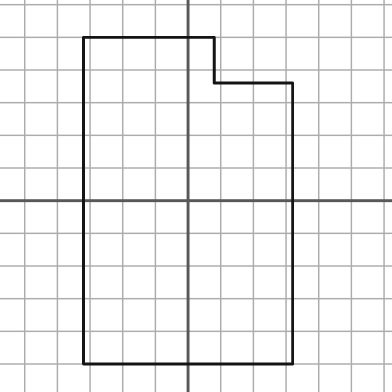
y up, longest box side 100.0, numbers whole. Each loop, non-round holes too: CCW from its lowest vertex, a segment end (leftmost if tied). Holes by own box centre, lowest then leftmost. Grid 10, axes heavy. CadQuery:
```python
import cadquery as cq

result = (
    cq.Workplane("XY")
    .moveTo(-32.0, -50.0)
    .lineTo(32.0, -50.0)
    .lineTo(32.0, 36.0)
    .lineTo(8.0, 36.0)
    .lineTo(8.0, 50.0)
    .lineTo(-32.0, 50.0)
    .close()
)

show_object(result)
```